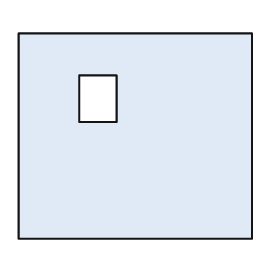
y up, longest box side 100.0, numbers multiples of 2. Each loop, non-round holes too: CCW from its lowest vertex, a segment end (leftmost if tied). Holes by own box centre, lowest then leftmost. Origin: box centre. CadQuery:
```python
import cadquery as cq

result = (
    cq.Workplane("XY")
    .moveTo(-50.0, -44.0)
    .lineTo(50.0, -44.0)
    .lineTo(50.0, 44.0)
    .lineTo(-50.0, 44.0)
    .close()
    .moveTo(-24.0, 6.0)
    .lineTo(-8.0, 6.0)
    .lineTo(-8.0, 26.0)
    .lineTo(-24.0, 26.0)
    .close()
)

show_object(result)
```